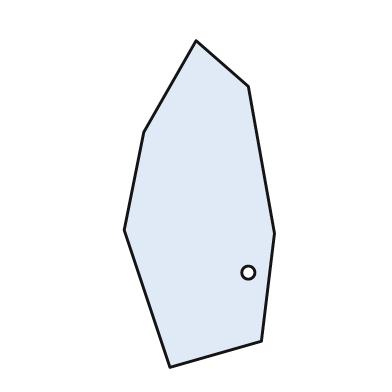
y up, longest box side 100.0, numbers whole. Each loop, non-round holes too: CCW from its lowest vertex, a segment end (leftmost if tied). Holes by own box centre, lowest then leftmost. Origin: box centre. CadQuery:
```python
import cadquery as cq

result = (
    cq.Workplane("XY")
    .moveTo(-9.0, -50.0)
    .lineTo(19.0, -42.0)
    .lineTo(23.0, -9.0)
    .lineTo(15.0, 36.0)
    .lineTo(-1.0, 50.0)
    .lineTo(-17.0, 22.0)
    .lineTo(-23.0, -8.0)
    .close()
    .moveTo(15.0, -21.0)
    .circle(2.0)
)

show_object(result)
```